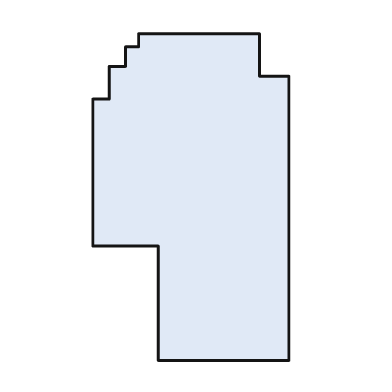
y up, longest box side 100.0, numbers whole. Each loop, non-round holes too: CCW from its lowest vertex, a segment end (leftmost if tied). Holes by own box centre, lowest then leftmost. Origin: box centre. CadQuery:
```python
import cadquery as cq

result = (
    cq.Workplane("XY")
    .moveTo(-10.0, -50.0)
    .lineTo(30.0, -50.0)
    .lineTo(30.0, 37.0)
    .lineTo(21.0, 37.0)
    .lineTo(21.0, 50.0)
    .lineTo(-16.0, 50.0)
    .lineTo(-16.0, 46.0)
    .lineTo(-20.0, 46.0)
    .lineTo(-20.0, 40.0)
    .lineTo(-25.0, 40.0)
    .lineTo(-25.0, 30.0)
    .lineTo(-30.0, 30.0)
    .lineTo(-30.0, -15.0)
    .lineTo(-10.0, -15.0)
    .close()
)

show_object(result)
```